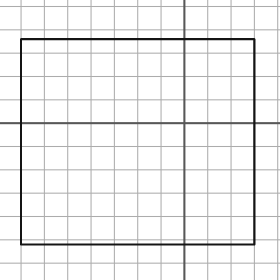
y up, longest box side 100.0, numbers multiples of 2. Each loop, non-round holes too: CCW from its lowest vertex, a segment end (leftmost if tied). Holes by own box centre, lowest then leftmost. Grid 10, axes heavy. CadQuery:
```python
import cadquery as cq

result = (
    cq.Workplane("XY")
    .moveTo(-70.0, -52.0)
    .lineTo(30.0, -52.0)
    .lineTo(30.0, 36.0)
    .lineTo(-70.0, 36.0)
    .close()
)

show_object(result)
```